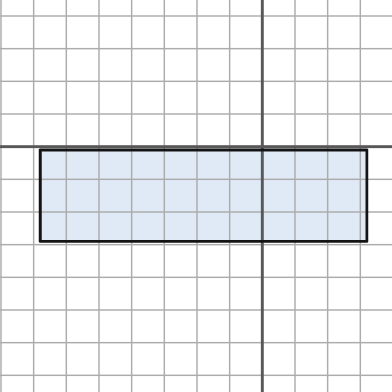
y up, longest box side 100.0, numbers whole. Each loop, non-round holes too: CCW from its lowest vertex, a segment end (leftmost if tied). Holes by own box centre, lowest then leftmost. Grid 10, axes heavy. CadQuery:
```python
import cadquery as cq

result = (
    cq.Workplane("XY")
    .moveTo(-68.0, -29.0)
    .lineTo(32.0, -29.0)
    .lineTo(32.0, -1.0)
    .lineTo(-68.0, -1.0)
    .close()
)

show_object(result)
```